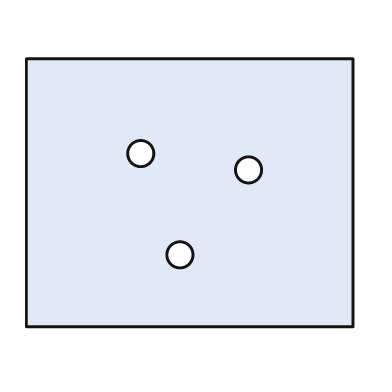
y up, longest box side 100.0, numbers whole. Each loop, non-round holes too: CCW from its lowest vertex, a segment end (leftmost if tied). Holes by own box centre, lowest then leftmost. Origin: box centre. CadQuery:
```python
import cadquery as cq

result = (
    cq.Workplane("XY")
    .moveTo(-50.0, -41.0)
    .lineTo(50.0, -41.0)
    .lineTo(50.0, 41.0)
    .lineTo(-50.0, 41.0)
    .close()
    .moveTo(-3.0, -19.0)
    .circle(4.0)
    .moveTo(18.0, 7.0)
    .circle(4.0)
    .moveTo(-15.0, 12.0)
    .circle(4.0)
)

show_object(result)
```